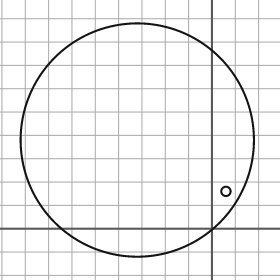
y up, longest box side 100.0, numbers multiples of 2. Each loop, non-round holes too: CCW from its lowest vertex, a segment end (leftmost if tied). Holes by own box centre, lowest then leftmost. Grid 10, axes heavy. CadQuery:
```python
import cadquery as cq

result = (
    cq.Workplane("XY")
    .moveTo(-32.0, 38.0)
    .circle(50.0)
    .moveTo(6.0, 16.0)
    .circle(2.0)
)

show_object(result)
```